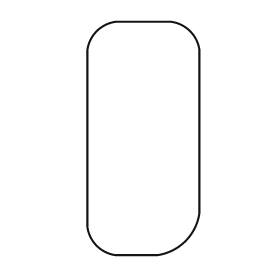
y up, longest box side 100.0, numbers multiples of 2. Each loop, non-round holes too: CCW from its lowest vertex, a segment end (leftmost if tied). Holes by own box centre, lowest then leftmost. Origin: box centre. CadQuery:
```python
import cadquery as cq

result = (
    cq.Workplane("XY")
    .moveTo(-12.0, -50.0)
    .lineTo(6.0, -50.0)
    .threePointArc((18.0, -44.0), (24.0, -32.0))
    .lineTo(24.0, 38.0)
    .threePointArc((20.0, 46.0), (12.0, 50.0))
    .lineTo(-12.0, 50.0)
    .threePointArc((-20.0, 46.0), (-24.0, 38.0))
    .lineTo(-24.0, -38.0)
    .threePointArc((-20.0, -46.0), (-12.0, -50.0))
    .close()
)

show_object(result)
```